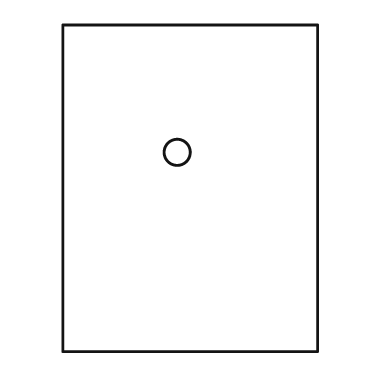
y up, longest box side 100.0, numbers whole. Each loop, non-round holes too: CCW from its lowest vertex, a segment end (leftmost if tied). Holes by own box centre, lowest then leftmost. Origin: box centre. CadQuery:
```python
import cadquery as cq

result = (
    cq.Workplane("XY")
    .moveTo(-39.0, -50.0)
    .lineTo(39.0, -50.0)
    .lineTo(39.0, 50.0)
    .lineTo(-39.0, 50.0)
    .close()
    .moveTo(-4.0, 11.0)
    .circle(4.0)
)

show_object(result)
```